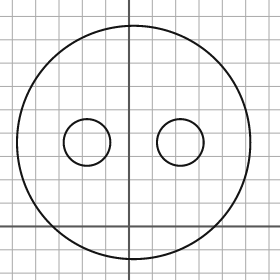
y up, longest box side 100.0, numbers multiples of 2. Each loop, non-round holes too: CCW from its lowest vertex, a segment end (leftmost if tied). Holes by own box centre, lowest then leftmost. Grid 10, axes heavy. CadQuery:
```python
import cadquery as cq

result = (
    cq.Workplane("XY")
    .moveTo(2.0, 36.0)
    .circle(50.0)
    .moveTo(-18.0, 36.0)
    .circle(10.0)
    .moveTo(22.0, 36.0)
    .circle(10.0)
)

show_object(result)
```